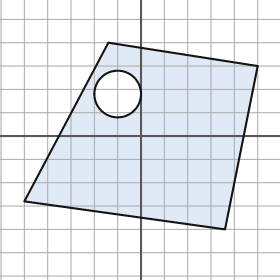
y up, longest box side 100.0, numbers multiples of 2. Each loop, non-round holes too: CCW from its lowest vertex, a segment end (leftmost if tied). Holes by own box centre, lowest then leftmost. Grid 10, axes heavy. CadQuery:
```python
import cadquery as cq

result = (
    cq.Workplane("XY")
    .moveTo(36.0, -40.0)
    .lineTo(50.0, 30.0)
    .lineTo(-14.0, 40.0)
    .lineTo(-50.0, -28.0)
    .close()
    .moveTo(-10.0, 18.0)
    .circle(10.0)
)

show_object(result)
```